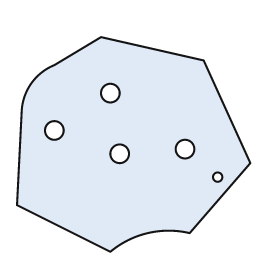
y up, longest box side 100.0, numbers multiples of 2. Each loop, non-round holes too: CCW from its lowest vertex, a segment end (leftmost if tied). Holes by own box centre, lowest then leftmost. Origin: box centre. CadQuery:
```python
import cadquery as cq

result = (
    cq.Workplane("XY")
    .moveTo(-10.0, -46.0)
    .threePointArc((6.0, -38.0), (24.0, -38.0))
    .lineTo(50.0, -8.0)
    .lineTo(30.0, 36.0)
    .lineTo(-14.0, 46.0)
    .lineTo(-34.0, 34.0)
    .threePointArc((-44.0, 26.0), (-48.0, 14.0))
    .lineTo(-50.0, -26.0)
    .close()
    .moveTo(36.0, -14.0)
    .circle(2.0)
    .moveTo(-6.0, -4.0)
    .circle(4.0)
    .moveTo(22.0, -2.0)
    .circle(4.0)
    .moveTo(-34.0, 6.0)
    .circle(4.0)
    .moveTo(-10.0, 22.0)
    .circle(4.0)
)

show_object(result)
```